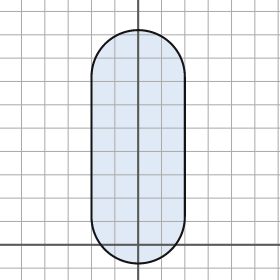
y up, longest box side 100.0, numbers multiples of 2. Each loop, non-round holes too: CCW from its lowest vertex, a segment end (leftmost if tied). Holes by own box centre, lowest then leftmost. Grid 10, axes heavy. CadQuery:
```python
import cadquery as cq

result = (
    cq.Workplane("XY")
    .moveTo(-20.0, 12.0)
    .threePointArc((0.0, -8.0), (20.0, 12.0))
    .lineTo(20.0, 72.0)
    .threePointArc((0.0, 92.0), (-20.0, 72.0))
    .close()
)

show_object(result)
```